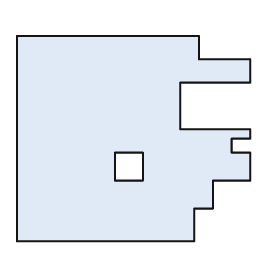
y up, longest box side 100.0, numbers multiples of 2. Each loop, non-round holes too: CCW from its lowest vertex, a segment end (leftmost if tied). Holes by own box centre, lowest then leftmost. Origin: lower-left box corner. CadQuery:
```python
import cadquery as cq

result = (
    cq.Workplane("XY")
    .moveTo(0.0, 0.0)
    .lineTo(76.0, 0.0)
    .lineTo(76.0, 14.0)
    .lineTo(84.0, 14.0)
    .lineTo(84.0, 26.0)
    .lineTo(100.0, 26.0)
    .lineTo(100.0, 38.0)
    .lineTo(92.0, 38.0)
    .lineTo(92.0, 44.0)
    .lineTo(100.0, 44.0)
    .lineTo(100.0, 48.0)
    .lineTo(70.0, 48.0)
    .lineTo(70.0, 68.0)
    .lineTo(100.0, 68.0)
    .lineTo(100.0, 78.0)
    .lineTo(78.0, 78.0)
    .lineTo(78.0, 88.0)
    .lineTo(0.0, 88.0)
    .close()
    .moveTo(42.0, 26.0)
    .lineTo(54.0, 26.0)
    .lineTo(54.0, 38.0)
    .lineTo(42.0, 38.0)
    .close()
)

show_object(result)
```